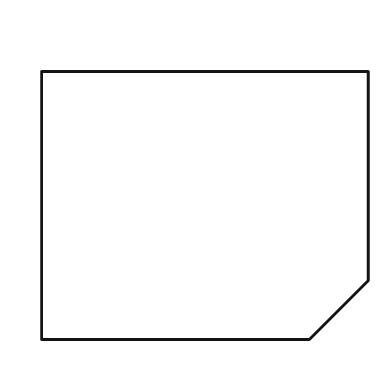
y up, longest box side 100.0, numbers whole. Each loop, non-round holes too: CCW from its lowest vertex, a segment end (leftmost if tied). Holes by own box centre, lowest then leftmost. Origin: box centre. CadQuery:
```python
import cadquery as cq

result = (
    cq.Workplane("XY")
    .moveTo(-50.0, -41.0)
    .lineTo(32.0, -41.0)
    .lineTo(50.0, -23.0)
    .lineTo(50.0, 41.0)
    .lineTo(-50.0, 41.0)
    .close()
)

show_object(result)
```